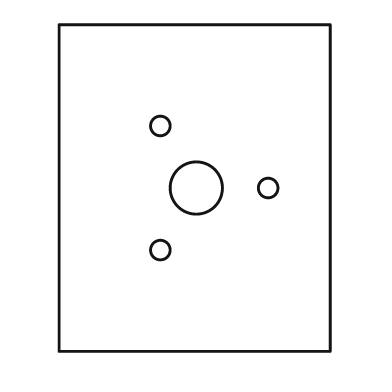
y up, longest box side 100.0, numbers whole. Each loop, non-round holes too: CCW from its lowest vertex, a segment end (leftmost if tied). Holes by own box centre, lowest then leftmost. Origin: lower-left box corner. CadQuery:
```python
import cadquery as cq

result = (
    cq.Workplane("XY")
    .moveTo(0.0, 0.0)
    .lineTo(83.0, 0.0)
    .lineTo(83.0, 100.0)
    .lineTo(0.0, 100.0)
    .close()
    .moveTo(31.0, 31.0)
    .circle(3.0)
    .moveTo(42.0, 50.0)
    .circle(8.0)
    .moveTo(64.0, 50.0)
    .circle(3.0)
    .moveTo(31.0, 69.0)
    .circle(3.0)
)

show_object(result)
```